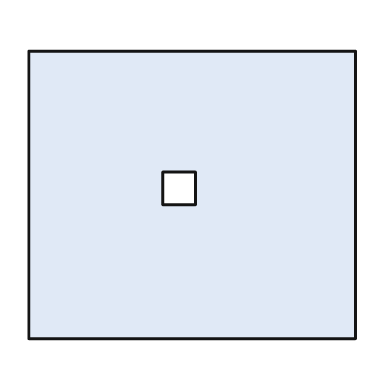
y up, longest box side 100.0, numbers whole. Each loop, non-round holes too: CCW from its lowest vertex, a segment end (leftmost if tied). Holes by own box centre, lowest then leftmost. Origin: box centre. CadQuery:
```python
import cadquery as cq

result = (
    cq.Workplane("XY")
    .moveTo(-50.0, -44.0)
    .lineTo(50.0, -44.0)
    .lineTo(50.0, 44.0)
    .lineTo(-50.0, 44.0)
    .close()
    .moveTo(-9.0, -3.0)
    .lineTo(1.0, -3.0)
    .lineTo(1.0, 7.0)
    .lineTo(-9.0, 7.0)
    .close()
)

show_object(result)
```